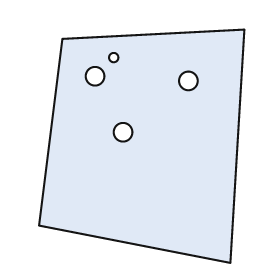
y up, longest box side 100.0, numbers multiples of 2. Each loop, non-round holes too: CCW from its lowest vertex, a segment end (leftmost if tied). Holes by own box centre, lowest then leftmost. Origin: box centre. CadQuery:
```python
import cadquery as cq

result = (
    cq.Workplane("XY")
    .moveTo(38.0, -50.0)
    .lineTo(44.0, 50.0)
    .lineTo(-34.0, 46.0)
    .lineTo(-44.0, -34.0)
    .close()
    .moveTo(-8.0, 6.0)
    .circle(4.0)
    .moveTo(20.0, 28.0)
    .circle(4.0)
    .moveTo(-20.0, 30.0)
    .circle(4.0)
    .moveTo(-12.0, 38.0)
    .circle(2.0)
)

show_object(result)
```